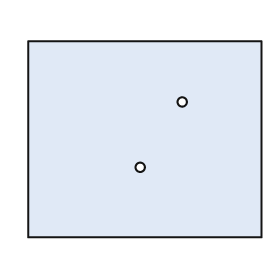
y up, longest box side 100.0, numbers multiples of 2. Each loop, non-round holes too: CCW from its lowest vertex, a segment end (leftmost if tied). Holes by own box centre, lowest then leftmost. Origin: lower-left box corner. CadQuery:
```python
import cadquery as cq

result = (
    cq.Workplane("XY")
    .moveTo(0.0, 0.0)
    .lineTo(100.0, 0.0)
    .lineTo(100.0, 84.0)
    .lineTo(0.0, 84.0)
    .close()
    .moveTo(48.0, 30.0)
    .circle(2.0)
    .moveTo(66.0, 58.0)
    .circle(2.0)
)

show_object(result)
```